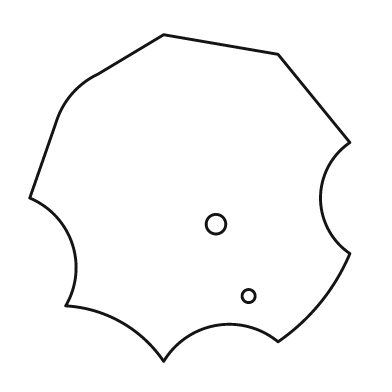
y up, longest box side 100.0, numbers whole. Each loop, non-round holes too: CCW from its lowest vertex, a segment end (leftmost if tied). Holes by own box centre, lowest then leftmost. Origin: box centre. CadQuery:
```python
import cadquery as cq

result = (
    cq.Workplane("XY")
    .moveTo(-8.0, -50.0)
    .threePointArc((8.0, -39.0), (27.0, -44.0))
    .threePointArc((40.0, -32.0), (49.0, -17.0))
    .threePointArc((40.0, 0.0), (49.0, 17.0))
    .lineTo(27.0, 44.0)
    .lineTo(-8.0, 50.0)
    .lineTo(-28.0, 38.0)
    .threePointArc((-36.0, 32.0), (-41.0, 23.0))
    .lineTo(-49.0, 0.0)
    .threePointArc((-36.0, -14.0), (-38.0, -33.0))
    .threePointArc((-21.0, -38.0), (-8.0, -50.0))
    .close()
    .moveTo(18.0, -30.0)
    .circle(2.0)
    .moveTo(8.0, -8.0)
    .circle(3.0)
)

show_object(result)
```